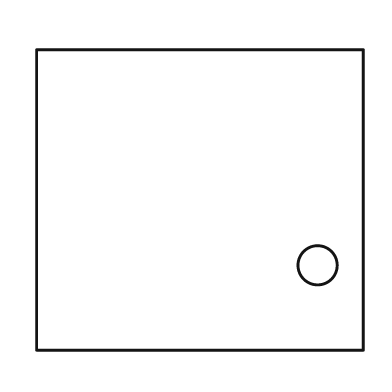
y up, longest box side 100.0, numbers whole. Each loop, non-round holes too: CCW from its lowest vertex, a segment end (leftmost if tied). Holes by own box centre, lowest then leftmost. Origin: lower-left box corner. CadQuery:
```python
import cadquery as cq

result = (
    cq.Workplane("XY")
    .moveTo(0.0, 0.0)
    .lineTo(100.0, 0.0)
    .lineTo(100.0, 92.0)
    .lineTo(0.0, 92.0)
    .close()
    .moveTo(86.0, 26.0)
    .circle(6.0)
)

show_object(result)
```